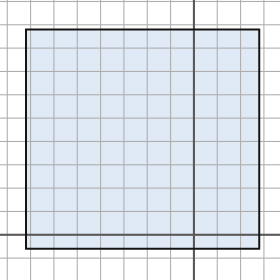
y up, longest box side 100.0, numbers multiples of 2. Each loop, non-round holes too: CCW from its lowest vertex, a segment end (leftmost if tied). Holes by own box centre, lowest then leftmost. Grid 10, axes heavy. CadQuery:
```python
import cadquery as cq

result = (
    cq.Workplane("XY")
    .moveTo(-72.0, -6.0)
    .lineTo(28.0, -6.0)
    .lineTo(28.0, 88.0)
    .lineTo(-72.0, 88.0)
    .close()
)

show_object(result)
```